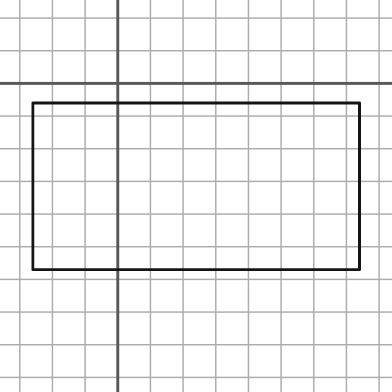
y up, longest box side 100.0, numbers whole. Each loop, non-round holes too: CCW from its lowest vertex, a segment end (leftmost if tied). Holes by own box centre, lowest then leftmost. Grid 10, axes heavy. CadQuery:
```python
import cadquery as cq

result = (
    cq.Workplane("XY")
    .moveTo(-26.0, -57.0)
    .lineTo(74.0, -57.0)
    .lineTo(74.0, -6.0)
    .lineTo(-26.0, -6.0)
    .close()
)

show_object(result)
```